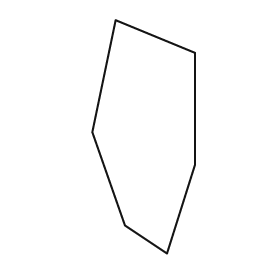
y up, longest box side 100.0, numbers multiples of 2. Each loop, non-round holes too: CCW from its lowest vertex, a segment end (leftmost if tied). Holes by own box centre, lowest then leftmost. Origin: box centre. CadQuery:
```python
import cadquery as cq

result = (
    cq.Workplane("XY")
    .moveTo(10.0, -50.0)
    .lineTo(22.0, -12.0)
    .lineTo(22.0, 36.0)
    .lineTo(-12.0, 50.0)
    .lineTo(-22.0, 2.0)
    .lineTo(-8.0, -38.0)
    .close()
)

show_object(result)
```